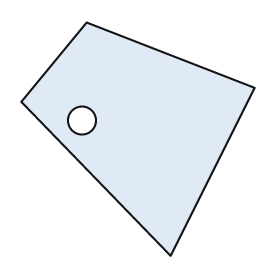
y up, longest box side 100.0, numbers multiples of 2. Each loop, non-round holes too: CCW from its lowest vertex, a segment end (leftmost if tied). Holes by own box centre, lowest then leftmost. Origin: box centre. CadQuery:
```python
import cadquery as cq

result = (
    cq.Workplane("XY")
    .moveTo(14.0, -50.0)
    .lineTo(50.0, 22.0)
    .lineTo(-22.0, 50.0)
    .lineTo(-50.0, 16.0)
    .close()
    .moveTo(-24.0, 8.0)
    .circle(6.0)
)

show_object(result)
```